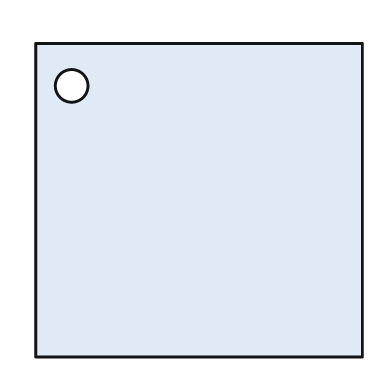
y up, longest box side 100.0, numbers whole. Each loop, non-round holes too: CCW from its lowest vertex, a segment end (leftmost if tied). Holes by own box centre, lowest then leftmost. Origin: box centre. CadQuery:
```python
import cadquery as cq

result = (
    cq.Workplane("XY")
    .moveTo(-50.0, -48.0)
    .lineTo(50.0, -48.0)
    .lineTo(50.0, 48.0)
    .lineTo(-50.0, 48.0)
    .close()
    .moveTo(-39.0, 35.0)
    .circle(5.0)
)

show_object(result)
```